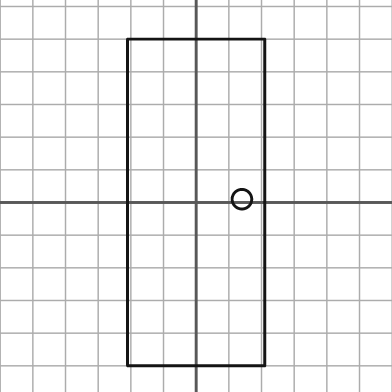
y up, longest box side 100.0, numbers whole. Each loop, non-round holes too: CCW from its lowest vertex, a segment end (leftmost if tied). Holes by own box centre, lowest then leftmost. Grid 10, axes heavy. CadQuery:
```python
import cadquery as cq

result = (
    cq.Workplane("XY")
    .moveTo(-21.0, -50.0)
    .lineTo(21.0, -50.0)
    .lineTo(21.0, 50.0)
    .lineTo(-21.0, 50.0)
    .close()
    .moveTo(14.0, 1.0)
    .circle(3.0)
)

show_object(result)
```